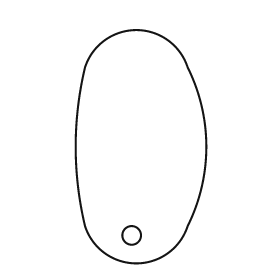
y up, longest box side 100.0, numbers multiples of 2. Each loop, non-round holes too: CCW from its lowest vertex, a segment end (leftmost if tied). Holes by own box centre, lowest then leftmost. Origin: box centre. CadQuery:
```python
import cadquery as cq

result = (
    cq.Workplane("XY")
    .moveTo(-24.0, -34.0)
    .threePointArc((-2.0, -50.0), (20.0, -34.0))
    .threePointArc((28.0, 0.0), (20.0, 34.0))
    .threePointArc((-2.0, 50.0), (-24.0, 34.0))
    .threePointArc((-28.0, 0.0), (-24.0, -34.0))
    .close()
    .moveTo(-4.0, -38.0)
    .circle(4.0)
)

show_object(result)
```